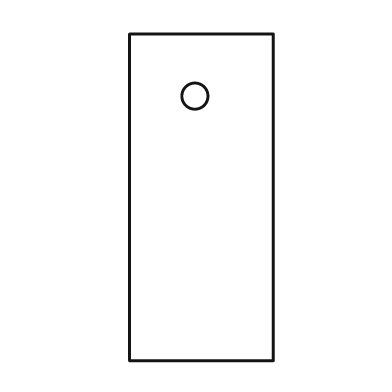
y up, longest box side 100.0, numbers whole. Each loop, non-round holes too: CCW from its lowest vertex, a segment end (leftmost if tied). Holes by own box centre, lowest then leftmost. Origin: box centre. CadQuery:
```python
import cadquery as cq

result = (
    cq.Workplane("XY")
    .moveTo(-22.0, -50.0)
    .lineTo(22.0, -50.0)
    .lineTo(22.0, 50.0)
    .lineTo(-22.0, 50.0)
    .close()
    .moveTo(-2.0, 31.0)
    .circle(4.0)
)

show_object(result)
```